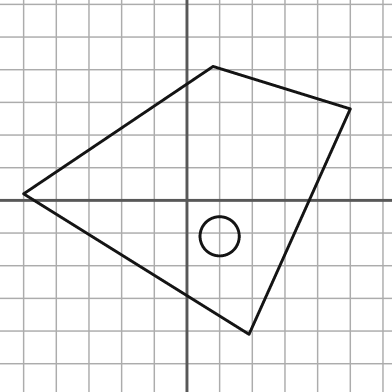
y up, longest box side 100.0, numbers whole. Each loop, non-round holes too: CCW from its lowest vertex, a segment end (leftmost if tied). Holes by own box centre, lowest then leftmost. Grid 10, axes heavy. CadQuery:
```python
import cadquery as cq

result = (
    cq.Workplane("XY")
    .moveTo(19.0, -41.0)
    .lineTo(50.0, 28.0)
    .lineTo(8.0, 41.0)
    .lineTo(-50.0, 2.0)
    .close()
    .moveTo(10.0, -11.0)
    .circle(6.0)
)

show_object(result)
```